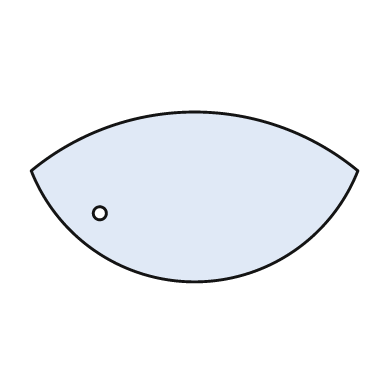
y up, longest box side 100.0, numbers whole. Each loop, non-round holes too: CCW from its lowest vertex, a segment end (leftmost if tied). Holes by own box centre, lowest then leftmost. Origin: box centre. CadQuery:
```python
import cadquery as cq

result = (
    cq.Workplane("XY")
    .moveTo(-50.0, 8.0)
    .threePointArc((0.0, -26.0), (50.0, 8.0))
    .threePointArc((0.0, 26.0), (-50.0, 8.0))
    .close()
    .moveTo(-29.0, -5.0)
    .circle(2.0)
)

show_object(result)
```